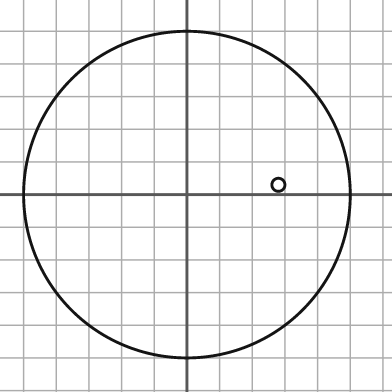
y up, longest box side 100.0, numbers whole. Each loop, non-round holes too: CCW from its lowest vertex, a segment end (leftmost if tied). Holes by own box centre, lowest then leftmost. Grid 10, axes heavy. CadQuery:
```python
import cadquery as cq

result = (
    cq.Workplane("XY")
    .moveTo(0.0, 0.0)
    .circle(50.0)
    .moveTo(28.0, 3.0)
    .circle(2.0)
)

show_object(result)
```